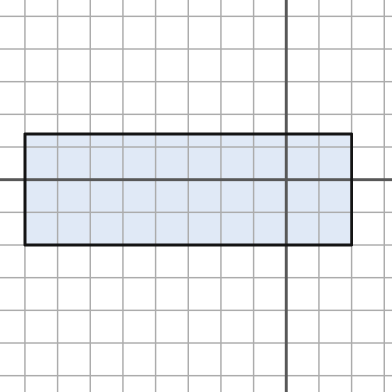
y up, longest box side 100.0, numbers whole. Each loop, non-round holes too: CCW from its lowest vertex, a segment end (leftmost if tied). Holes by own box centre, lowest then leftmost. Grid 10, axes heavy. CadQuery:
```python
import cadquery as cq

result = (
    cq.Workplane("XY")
    .moveTo(-80.0, -20.0)
    .lineTo(20.0, -20.0)
    .lineTo(20.0, 14.0)
    .lineTo(-80.0, 14.0)
    .close()
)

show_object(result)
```